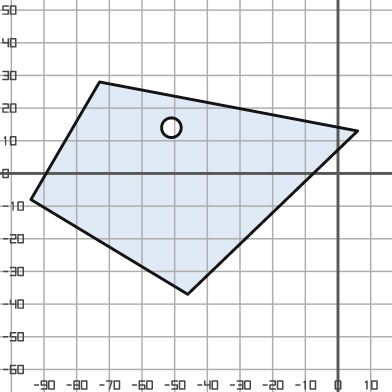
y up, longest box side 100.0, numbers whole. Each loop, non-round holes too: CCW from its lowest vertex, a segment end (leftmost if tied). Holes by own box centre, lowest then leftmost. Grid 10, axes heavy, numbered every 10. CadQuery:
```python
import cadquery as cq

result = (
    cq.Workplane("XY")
    .moveTo(-46.0, -37.0)
    .lineTo(6.0, 13.0)
    .lineTo(-73.0, 28.0)
    .lineTo(-94.0, -8.0)
    .close()
    .moveTo(-51.0, 14.0)
    .circle(3.0)
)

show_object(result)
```